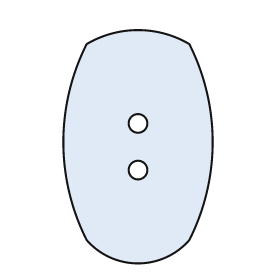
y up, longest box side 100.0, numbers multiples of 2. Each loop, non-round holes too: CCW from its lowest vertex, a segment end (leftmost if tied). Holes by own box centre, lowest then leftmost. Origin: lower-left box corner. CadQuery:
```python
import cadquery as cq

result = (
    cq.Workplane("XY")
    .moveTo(10.0, 10.0)
    .threePointArc((32.0, 0.0), (54.0, 10.0))
    .threePointArc((64.0, 52.0), (54.0, 94.0))
    .threePointArc((32.0, 100.0), (10.0, 94.0))
    .threePointArc((0.0, 52.0), (10.0, 10.0))
    .close()
    .moveTo(32.0, 40.0)
    .circle(4.0)
    .moveTo(32.0, 60.0)
    .circle(4.0)
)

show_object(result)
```